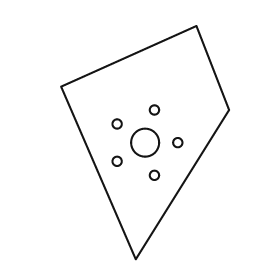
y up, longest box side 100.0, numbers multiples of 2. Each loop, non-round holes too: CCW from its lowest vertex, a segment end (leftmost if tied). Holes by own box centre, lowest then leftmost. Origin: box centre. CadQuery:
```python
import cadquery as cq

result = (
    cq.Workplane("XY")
    .moveTo(-4.0, -50.0)
    .lineTo(36.0, 14.0)
    .lineTo(22.0, 50.0)
    .lineTo(-36.0, 24.0)
    .close()
    .moveTo(4.0, -14.0)
    .circle(2.0)
    .moveTo(-12.0, -8.0)
    .circle(2.0)
    .moveTo(0.0, 0.0)
    .circle(6.0)
    .moveTo(14.0, 0.0)
    .circle(2.0)
    .moveTo(-12.0, 8.0)
    .circle(2.0)
    .moveTo(4.0, 14.0)
    .circle(2.0)
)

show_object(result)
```